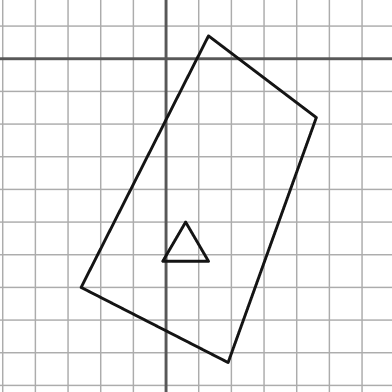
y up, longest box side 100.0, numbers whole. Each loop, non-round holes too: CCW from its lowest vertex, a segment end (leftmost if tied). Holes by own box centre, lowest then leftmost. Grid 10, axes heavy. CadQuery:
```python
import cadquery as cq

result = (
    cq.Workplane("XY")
    .moveTo(19.0, -93.0)
    .lineTo(46.0, -18.0)
    .lineTo(13.0, 7.0)
    .lineTo(-26.0, -70.0)
    .close()
    .moveTo(-1.0, -62.0)
    .lineTo(13.0, -62.0)
    .lineTo(6.0, -50.0)
    .close()
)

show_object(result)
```